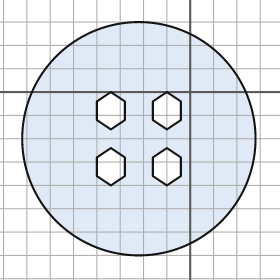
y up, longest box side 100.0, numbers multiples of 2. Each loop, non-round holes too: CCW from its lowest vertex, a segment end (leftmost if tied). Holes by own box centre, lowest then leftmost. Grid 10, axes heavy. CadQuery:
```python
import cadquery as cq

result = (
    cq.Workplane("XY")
    .moveTo(-22.0, -20.0)
    .circle(50.0)
    .moveTo(-34.0, -40.0)
    .lineTo(-28.0, -36.0)
    .lineTo(-28.0, -28.0)
    .lineTo(-34.0, -24.0)
    .lineTo(-40.0, -28.0)
    .lineTo(-40.0, -36.0)
    .close()
    .moveTo(-10.0, -40.0)
    .lineTo(-4.0, -36.0)
    .lineTo(-4.0, -28.0)
    .lineTo(-10.0, -24.0)
    .lineTo(-16.0, -28.0)
    .lineTo(-16.0, -36.0)
    .close()
    .moveTo(-34.0, -16.0)
    .lineTo(-28.0, -12.0)
    .lineTo(-28.0, -4.0)
    .lineTo(-34.0, 0.0)
    .lineTo(-40.0, -4.0)
    .lineTo(-40.0, -12.0)
    .close()
    .moveTo(-10.0, -16.0)
    .lineTo(-4.0, -12.0)
    .lineTo(-4.0, -4.0)
    .lineTo(-10.0, 0.0)
    .lineTo(-16.0, -4.0)
    .lineTo(-16.0, -12.0)
    .close()
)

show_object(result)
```